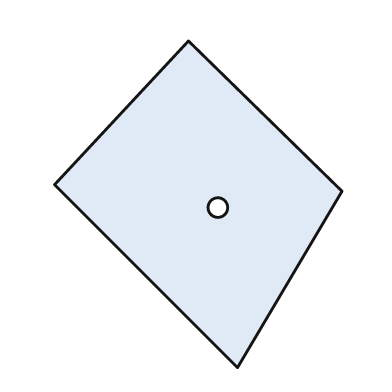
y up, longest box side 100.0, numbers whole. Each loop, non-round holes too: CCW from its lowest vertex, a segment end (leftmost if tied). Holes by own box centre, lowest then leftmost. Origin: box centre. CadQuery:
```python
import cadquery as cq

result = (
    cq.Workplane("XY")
    .moveTo(12.0, -50.0)
    .lineTo(44.0, 4.0)
    .lineTo(-3.0, 50.0)
    .lineTo(-44.0, 6.0)
    .close()
    .moveTo(6.0, -1.0)
    .circle(3.0)
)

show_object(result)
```